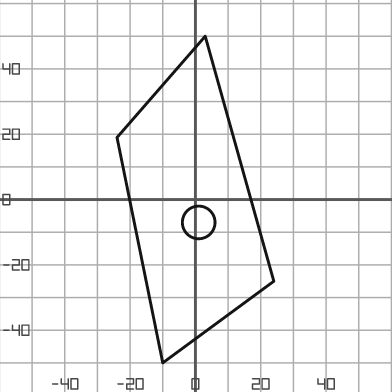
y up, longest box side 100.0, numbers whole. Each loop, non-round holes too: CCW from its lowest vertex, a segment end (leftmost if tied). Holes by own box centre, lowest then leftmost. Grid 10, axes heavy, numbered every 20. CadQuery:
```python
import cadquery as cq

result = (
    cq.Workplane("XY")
    .moveTo(-10.0, -50.0)
    .lineTo(24.0, -25.0)
    .lineTo(3.0, 50.0)
    .lineTo(-24.0, 19.0)
    .close()
    .moveTo(1.0, -7.0)
    .circle(5.0)
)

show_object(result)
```